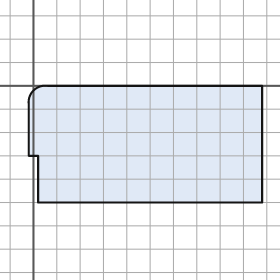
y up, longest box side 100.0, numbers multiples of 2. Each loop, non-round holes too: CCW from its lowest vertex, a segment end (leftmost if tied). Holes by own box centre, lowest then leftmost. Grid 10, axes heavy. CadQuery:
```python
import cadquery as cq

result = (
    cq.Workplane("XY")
    .moveTo(2.0, -50.0)
    .lineTo(98.0, -50.0)
    .lineTo(98.0, 0.0)
    .lineTo(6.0, 0.0)
    .threePointArc((0.0, -2.0), (-2.0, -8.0))
    .lineTo(-2.0, -30.0)
    .lineTo(2.0, -30.0)
    .close()
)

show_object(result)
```